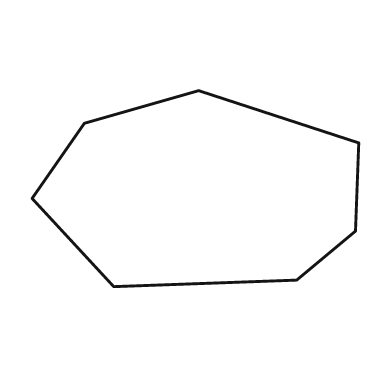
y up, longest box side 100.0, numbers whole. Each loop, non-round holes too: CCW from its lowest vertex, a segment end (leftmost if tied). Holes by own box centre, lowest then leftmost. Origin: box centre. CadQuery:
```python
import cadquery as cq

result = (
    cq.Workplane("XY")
    .moveTo(-25.0, -30.0)
    .lineTo(31.0, -28.0)
    .lineTo(49.0, -13.0)
    .lineTo(50.0, 14.0)
    .lineTo(1.0, 30.0)
    .lineTo(-34.0, 20.0)
    .lineTo(-50.0, -3.0)
    .close()
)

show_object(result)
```